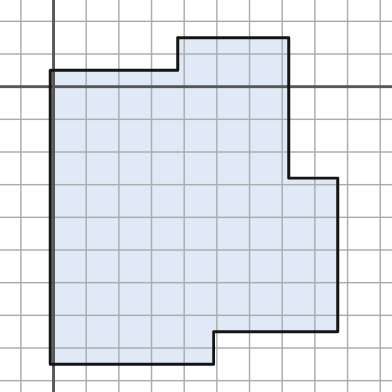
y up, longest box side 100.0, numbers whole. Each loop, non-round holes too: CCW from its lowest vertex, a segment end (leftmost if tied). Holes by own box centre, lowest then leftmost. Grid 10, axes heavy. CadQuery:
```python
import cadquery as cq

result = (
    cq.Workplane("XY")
    .moveTo(-1.0, -85.0)
    .lineTo(49.0, -85.0)
    .lineTo(49.0, -75.0)
    .lineTo(87.0, -75.0)
    .lineTo(87.0, -28.0)
    .lineTo(72.0, -28.0)
    .lineTo(72.0, 15.0)
    .lineTo(38.0, 15.0)
    .lineTo(38.0, 5.0)
    .lineTo(-1.0, 5.0)
    .close()
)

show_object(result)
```